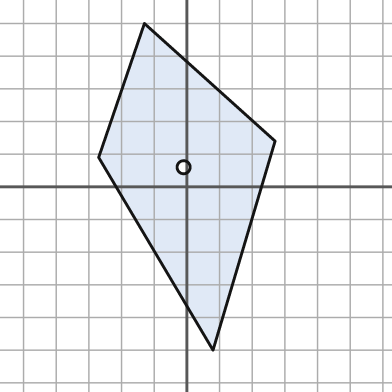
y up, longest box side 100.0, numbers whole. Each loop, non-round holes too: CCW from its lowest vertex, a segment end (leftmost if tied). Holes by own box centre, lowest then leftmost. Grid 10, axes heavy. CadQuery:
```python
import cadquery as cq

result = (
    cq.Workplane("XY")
    .moveTo(8.0, -50.0)
    .lineTo(27.0, 14.0)
    .lineTo(-13.0, 50.0)
    .lineTo(-27.0, 9.0)
    .close()
    .moveTo(-1.0, 6.0)
    .circle(2.0)
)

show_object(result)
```